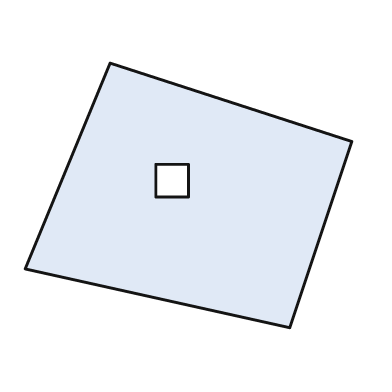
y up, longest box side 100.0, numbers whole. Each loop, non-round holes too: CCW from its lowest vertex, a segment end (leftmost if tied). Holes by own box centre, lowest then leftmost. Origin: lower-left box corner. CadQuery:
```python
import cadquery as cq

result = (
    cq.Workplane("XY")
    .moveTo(81.0, 0.0)
    .lineTo(100.0, 57.0)
    .lineTo(26.0, 81.0)
    .lineTo(0.0, 18.0)
    .close()
    .moveTo(40.0, 40.0)
    .lineTo(50.0, 40.0)
    .lineTo(50.0, 50.0)
    .lineTo(40.0, 50.0)
    .close()
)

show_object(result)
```